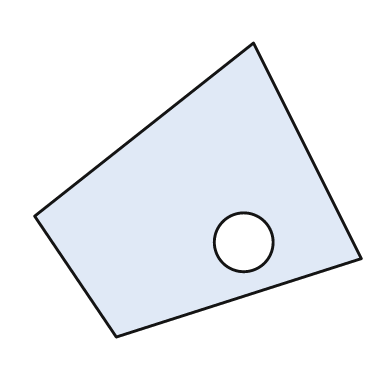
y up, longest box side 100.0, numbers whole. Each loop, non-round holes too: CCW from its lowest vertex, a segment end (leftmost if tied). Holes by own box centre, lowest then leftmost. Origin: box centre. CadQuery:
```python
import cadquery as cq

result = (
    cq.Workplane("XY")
    .moveTo(-25.0, -45.0)
    .lineTo(50.0, -21.0)
    .lineTo(17.0, 45.0)
    .lineTo(-50.0, -8.0)
    .close()
    .moveTo(14.0, -16.0)
    .circle(9.0)
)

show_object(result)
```